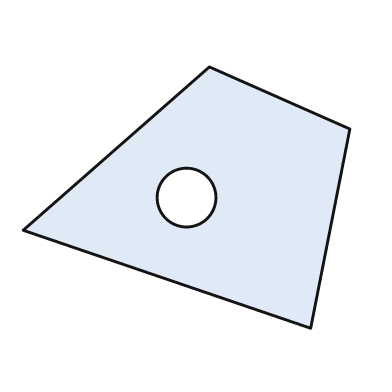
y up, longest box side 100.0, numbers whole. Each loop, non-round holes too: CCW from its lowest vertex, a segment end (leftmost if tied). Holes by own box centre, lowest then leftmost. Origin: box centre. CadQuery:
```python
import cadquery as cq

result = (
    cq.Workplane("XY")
    .moveTo(38.0, -40.0)
    .lineTo(50.0, 21.0)
    .lineTo(7.0, 40.0)
    .lineTo(-50.0, -10.0)
    .close()
    .moveTo(0.0, 0.0)
    .circle(9.0)
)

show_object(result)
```